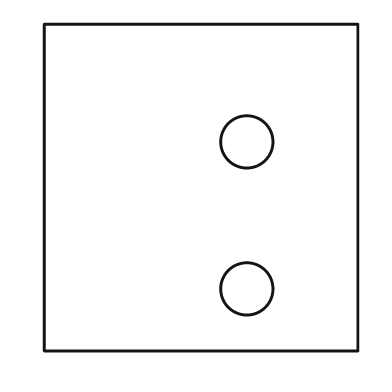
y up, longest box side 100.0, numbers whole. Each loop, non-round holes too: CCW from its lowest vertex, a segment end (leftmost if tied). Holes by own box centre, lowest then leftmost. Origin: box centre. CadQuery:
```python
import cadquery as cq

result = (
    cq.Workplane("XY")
    .moveTo(-48.0, -50.0)
    .lineTo(48.0, -50.0)
    .lineTo(48.0, 50.0)
    .lineTo(-48.0, 50.0)
    .close()
    .moveTo(14.0, -31.0)
    .circle(8.0)
    .moveTo(14.0, 14.0)
    .circle(8.0)
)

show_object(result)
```